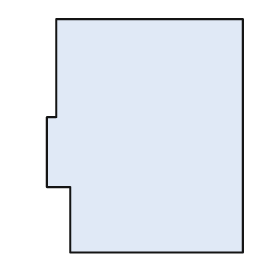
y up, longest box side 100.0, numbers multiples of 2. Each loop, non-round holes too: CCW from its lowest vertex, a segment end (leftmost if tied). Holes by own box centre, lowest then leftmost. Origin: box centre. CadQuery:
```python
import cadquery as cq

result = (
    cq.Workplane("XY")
    .moveTo(-32.0, -50.0)
    .lineTo(42.0, -50.0)
    .lineTo(42.0, 50.0)
    .lineTo(-38.0, 50.0)
    .lineTo(-38.0, 8.0)
    .lineTo(-42.0, 8.0)
    .lineTo(-42.0, -22.0)
    .lineTo(-32.0, -22.0)
    .close()
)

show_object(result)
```